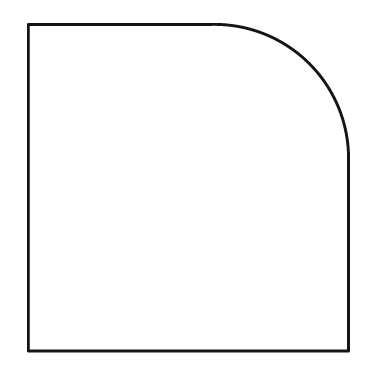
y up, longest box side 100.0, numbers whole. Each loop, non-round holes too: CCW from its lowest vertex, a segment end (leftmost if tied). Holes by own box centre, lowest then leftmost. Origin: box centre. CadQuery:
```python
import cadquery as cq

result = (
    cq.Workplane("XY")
    .moveTo(-49.0, -50.0)
    .lineTo(49.0, -50.0)
    .lineTo(49.0, 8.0)
    .threePointArc((37.0, 38.0), (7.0, 50.0))
    .lineTo(-49.0, 50.0)
    .close()
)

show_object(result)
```